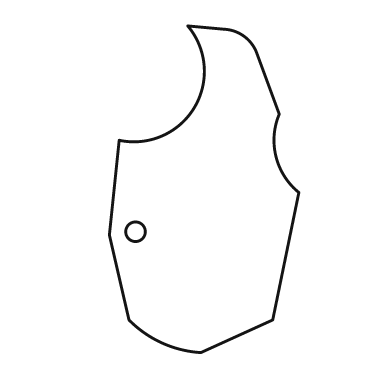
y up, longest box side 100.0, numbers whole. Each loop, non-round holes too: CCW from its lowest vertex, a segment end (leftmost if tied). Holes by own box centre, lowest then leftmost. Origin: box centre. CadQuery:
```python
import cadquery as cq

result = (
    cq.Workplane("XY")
    .moveTo(-1.0, -50.0)
    .lineTo(21.0, -40.0)
    .lineTo(29.0, -1.0)
    .threePointArc((22.0, 10.0), (23.0, 23.0))
    .lineTo(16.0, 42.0)
    .threePointArc((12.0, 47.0), (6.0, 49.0))
    .lineTo(-5.0, 50.0)
    .threePointArc((-3.0, 25.0), (-26.0, 15.0))
    .lineTo(-29.0, -14.0)
    .lineTo(-23.0, -40.0)
    .threePointArc((-13.0, -47.0), (-1.0, -50.0))
    .close()
    .moveTo(-21.0, -13.0)
    .circle(3.0)
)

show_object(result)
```